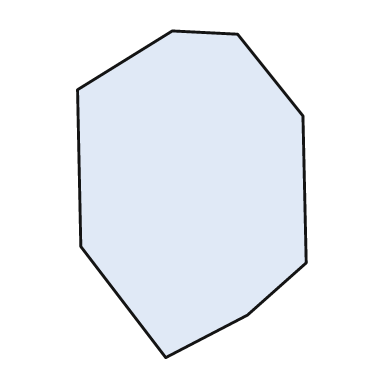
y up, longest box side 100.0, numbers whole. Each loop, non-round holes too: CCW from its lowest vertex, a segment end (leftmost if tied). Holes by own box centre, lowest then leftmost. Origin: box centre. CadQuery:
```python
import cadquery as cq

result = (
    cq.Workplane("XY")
    .moveTo(-8.0, -50.0)
    .lineTo(17.0, -37.0)
    .lineTo(35.0, -21.0)
    .lineTo(34.0, 24.0)
    .lineTo(14.0, 49.0)
    .lineTo(-6.0, 50.0)
    .lineTo(-35.0, 32.0)
    .lineTo(-34.0, -16.0)
    .close()
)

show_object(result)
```